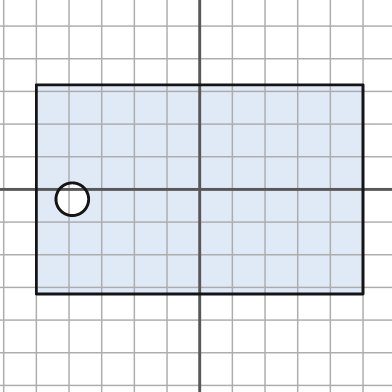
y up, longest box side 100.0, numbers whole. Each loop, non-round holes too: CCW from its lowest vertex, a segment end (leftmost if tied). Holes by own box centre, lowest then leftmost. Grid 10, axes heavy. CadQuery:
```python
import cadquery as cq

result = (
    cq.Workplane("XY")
    .moveTo(-50.0, -32.0)
    .lineTo(50.0, -32.0)
    .lineTo(50.0, 32.0)
    .lineTo(-50.0, 32.0)
    .close()
    .moveTo(-39.0, -3.0)
    .circle(5.0)
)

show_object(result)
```